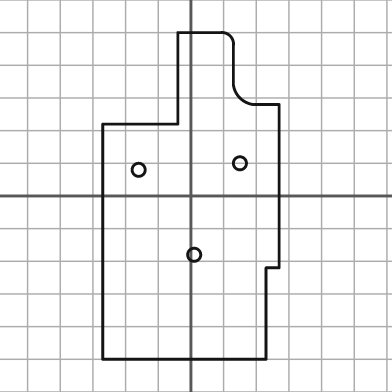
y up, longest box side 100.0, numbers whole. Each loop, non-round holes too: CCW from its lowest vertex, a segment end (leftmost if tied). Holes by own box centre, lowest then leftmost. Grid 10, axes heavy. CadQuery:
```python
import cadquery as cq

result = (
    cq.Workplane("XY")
    .moveTo(-27.0, -50.0)
    .lineTo(23.0, -50.0)
    .lineTo(23.0, -22.0)
    .lineTo(27.0, -22.0)
    .lineTo(27.0, 28.0)
    .lineTo(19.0, 28.0)
    .threePointArc((15.0, 30.0), (13.0, 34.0))
    .lineTo(13.0, 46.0)
    .threePointArc((12.0, 49.0), (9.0, 50.0))
    .lineTo(-4.0, 50.0)
    .lineTo(-4.0, 22.0)
    .lineTo(-27.0, 22.0)
    .close()
    .moveTo(1.0, -18.0)
    .circle(2.0)
    .moveTo(-16.0, 8.0)
    .circle(2.0)
    .moveTo(15.0, 10.0)
    .circle(2.0)
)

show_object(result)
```